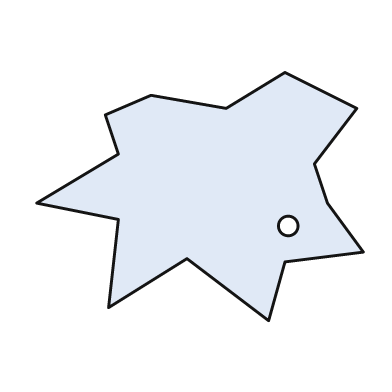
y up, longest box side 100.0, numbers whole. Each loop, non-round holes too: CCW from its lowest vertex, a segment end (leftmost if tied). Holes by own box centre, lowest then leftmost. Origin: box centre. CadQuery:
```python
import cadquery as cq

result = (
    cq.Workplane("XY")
    .moveTo(21.0, -38.0)
    .lineTo(26.0, -20.0)
    .lineTo(50.0, -17.0)
    .lineTo(39.0, -2.0)
    .lineTo(35.0, 10.0)
    .lineTo(48.0, 27.0)
    .lineTo(26.0, 38.0)
    .lineTo(8.0, 27.0)
    .lineTo(-15.0, 31.0)
    .lineTo(-29.0, 25.0)
    .lineTo(-25.0, 13.0)
    .lineTo(-50.0, -2.0)
    .lineTo(-25.0, -7.0)
    .lineTo(-28.0, -34.0)
    .lineTo(-4.0, -19.0)
    .close()
    .moveTo(27.0, -9.0)
    .circle(3.0)
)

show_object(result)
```